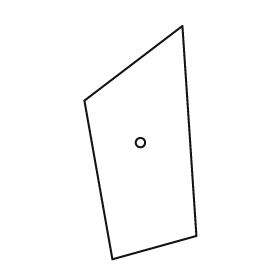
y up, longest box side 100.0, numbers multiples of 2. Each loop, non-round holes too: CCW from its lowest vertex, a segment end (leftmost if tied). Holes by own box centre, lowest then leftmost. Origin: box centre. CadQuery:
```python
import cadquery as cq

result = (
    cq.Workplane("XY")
    .moveTo(-12.0, -50.0)
    .lineTo(24.0, -40.0)
    .lineTo(18.0, 50.0)
    .lineTo(-24.0, 18.0)
    .close()
    .moveTo(0.0, 0.0)
    .circle(2.0)
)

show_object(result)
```